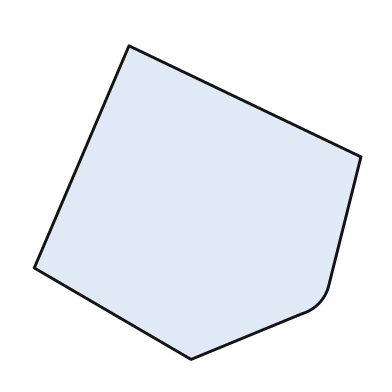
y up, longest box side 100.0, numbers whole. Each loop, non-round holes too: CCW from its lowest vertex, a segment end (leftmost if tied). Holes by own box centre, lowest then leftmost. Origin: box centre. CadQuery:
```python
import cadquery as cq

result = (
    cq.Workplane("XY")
    .moveTo(-2.0, -48.0)
    .lineTo(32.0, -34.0)
    .threePointArc((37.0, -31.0), (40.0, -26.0))
    .lineTo(50.0, 14.0)
    .lineTo(-21.0, 48.0)
    .lineTo(-50.0, -20.0)
    .close()
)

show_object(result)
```